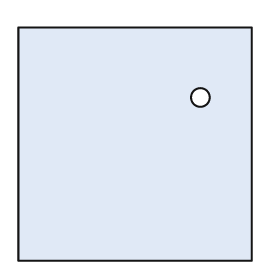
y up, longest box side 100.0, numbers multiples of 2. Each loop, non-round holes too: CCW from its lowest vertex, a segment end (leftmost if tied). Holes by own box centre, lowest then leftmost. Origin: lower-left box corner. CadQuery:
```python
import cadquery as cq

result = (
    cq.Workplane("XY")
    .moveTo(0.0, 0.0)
    .lineTo(100.0, 0.0)
    .lineTo(100.0, 100.0)
    .lineTo(0.0, 100.0)
    .close()
    .moveTo(78.0, 70.0)
    .circle(4.0)
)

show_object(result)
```